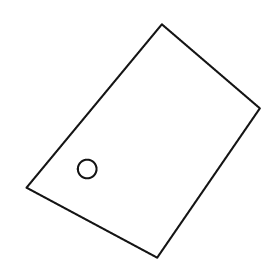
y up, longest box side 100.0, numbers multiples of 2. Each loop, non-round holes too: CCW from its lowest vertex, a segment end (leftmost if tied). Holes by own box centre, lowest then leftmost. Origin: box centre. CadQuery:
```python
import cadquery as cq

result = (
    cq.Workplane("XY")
    .moveTo(6.0, -50.0)
    .lineTo(50.0, 14.0)
    .lineTo(8.0, 50.0)
    .lineTo(-50.0, -20.0)
    .close()
    .moveTo(-24.0, -12.0)
    .circle(4.0)
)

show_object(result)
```